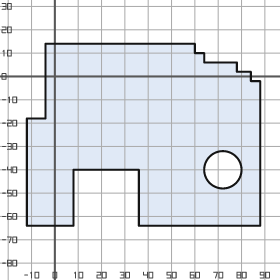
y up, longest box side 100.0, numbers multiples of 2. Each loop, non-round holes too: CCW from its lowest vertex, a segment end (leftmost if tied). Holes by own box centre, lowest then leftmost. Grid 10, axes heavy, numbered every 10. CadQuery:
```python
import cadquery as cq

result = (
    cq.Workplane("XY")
    .moveTo(-12.0, -64.0)
    .lineTo(8.0, -64.0)
    .lineTo(8.0, -40.0)
    .lineTo(36.0, -40.0)
    .lineTo(36.0, -64.0)
    .lineTo(88.0, -64.0)
    .lineTo(88.0, -2.0)
    .lineTo(84.0, -2.0)
    .lineTo(84.0, 2.0)
    .lineTo(78.0, 2.0)
    .lineTo(78.0, 6.0)
    .lineTo(64.0, 6.0)
    .lineTo(64.0, 10.0)
    .lineTo(60.0, 10.0)
    .lineTo(60.0, 14.0)
    .lineTo(-4.0, 14.0)
    .lineTo(-4.0, -18.0)
    .lineTo(-12.0, -18.0)
    .close()
    .moveTo(72.0, -40.0)
    .circle(8.0)
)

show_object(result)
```